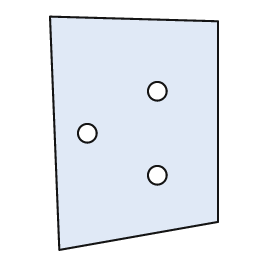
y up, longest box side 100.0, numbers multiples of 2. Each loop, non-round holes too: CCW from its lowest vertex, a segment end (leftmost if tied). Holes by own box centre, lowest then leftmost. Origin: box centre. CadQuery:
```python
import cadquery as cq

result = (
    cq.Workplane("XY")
    .moveTo(-32.0, -50.0)
    .lineTo(36.0, -38.0)
    .lineTo(36.0, 48.0)
    .lineTo(-36.0, 50.0)
    .close()
    .moveTo(10.0, -18.0)
    .circle(4.0)
    .moveTo(-20.0, 0.0)
    .circle(4.0)
    .moveTo(10.0, 18.0)
    .circle(4.0)
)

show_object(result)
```